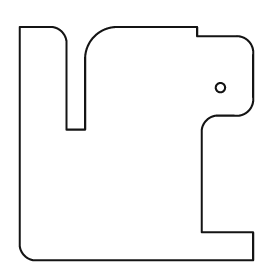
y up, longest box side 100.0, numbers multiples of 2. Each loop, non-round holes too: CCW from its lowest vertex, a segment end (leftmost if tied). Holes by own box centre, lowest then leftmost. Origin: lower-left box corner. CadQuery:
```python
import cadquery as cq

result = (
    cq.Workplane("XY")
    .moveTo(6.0, 0.0)
    .lineTo(100.0, 0.0)
    .lineTo(100.0, 12.0)
    .lineTo(78.0, 12.0)
    .lineTo(78.0, 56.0)
    .threePointArc((80.0, 60.0), (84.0, 62.0))
    .lineTo(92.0, 62.0)
    .threePointArc((98.0, 64.0), (100.0, 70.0))
    .lineTo(100.0, 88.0)
    .threePointArc((98.0, 94.0), (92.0, 96.0))
    .lineTo(76.0, 96.0)
    .lineTo(76.0, 100.0)
    .lineTo(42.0, 100.0)
    .threePointArc((32.0, 96.0), (28.0, 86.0))
    .lineTo(28.0, 56.0)
    .lineTo(20.0, 56.0)
    .lineTo(20.0, 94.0)
    .threePointArc((18.0, 98.0), (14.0, 100.0))
    .lineTo(0.0, 100.0)
    .lineTo(0.0, 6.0)
    .threePointArc((2.0, 2.0), (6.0, 0.0))
    .close()
    .moveTo(86.0, 74.0)
    .circle(2.0)
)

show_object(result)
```